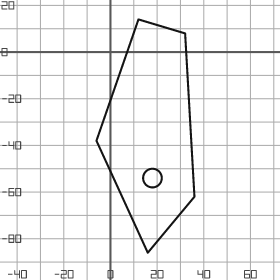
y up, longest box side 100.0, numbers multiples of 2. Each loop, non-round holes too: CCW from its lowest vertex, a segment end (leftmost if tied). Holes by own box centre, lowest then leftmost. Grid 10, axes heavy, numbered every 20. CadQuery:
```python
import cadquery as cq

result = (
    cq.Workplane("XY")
    .moveTo(16.0, -86.0)
    .lineTo(36.0, -62.0)
    .lineTo(32.0, 8.0)
    .lineTo(12.0, 14.0)
    .lineTo(-6.0, -38.0)
    .close()
    .moveTo(18.0, -54.0)
    .circle(4.0)
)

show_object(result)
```